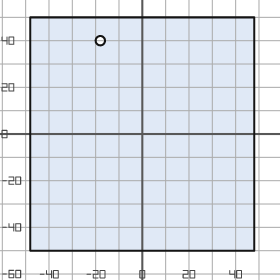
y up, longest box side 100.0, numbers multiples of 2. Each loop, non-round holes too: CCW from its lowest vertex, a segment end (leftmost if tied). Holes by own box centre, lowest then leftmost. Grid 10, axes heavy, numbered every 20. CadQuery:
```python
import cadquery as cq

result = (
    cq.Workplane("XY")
    .moveTo(-48.0, -50.0)
    .lineTo(48.0, -50.0)
    .lineTo(48.0, 50.0)
    .lineTo(-48.0, 50.0)
    .close()
    .moveTo(-18.0, 40.0)
    .circle(2.0)
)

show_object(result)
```